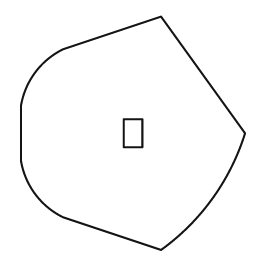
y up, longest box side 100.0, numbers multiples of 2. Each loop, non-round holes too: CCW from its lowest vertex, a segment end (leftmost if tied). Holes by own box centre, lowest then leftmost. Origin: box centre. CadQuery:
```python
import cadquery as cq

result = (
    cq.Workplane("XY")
    .moveTo(12.0, -50.0)
    .threePointArc((34.0, -28.0), (48.0, 0.0))
    .lineTo(12.0, 50.0)
    .lineTo(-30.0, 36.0)
    .threePointArc((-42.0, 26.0), (-48.0, 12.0))
    .lineTo(-48.0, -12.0)
    .threePointArc((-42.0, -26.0), (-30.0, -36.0))
    .close()
    .moveTo(-4.0, -6.0)
    .lineTo(4.0, -6.0)
    .lineTo(4.0, 6.0)
    .lineTo(-4.0, 6.0)
    .close()
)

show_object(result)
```